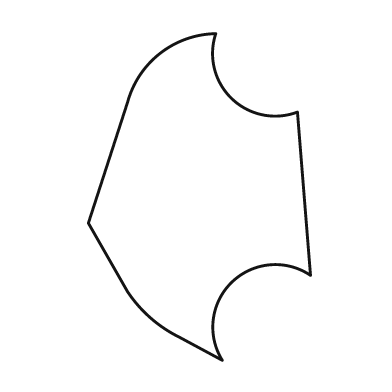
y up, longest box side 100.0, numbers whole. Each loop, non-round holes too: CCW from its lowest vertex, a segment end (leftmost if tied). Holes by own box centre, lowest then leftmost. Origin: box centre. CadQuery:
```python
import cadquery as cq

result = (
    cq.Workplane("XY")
    .moveTo(7.0, -50.0)
    .threePointArc((10.0, -26.0), (34.0, -24.0))
    .lineTo(30.0, 26.0)
    .threePointArc((10.0, 30.0), (5.0, 50.0))
    .threePointArc((-12.0, 44.0), (-22.0, 29.0))
    .lineTo(-34.0, -8.0)
    .lineTo(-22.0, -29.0)
    .threePointArc((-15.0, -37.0), (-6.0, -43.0))
    .close()
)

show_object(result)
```